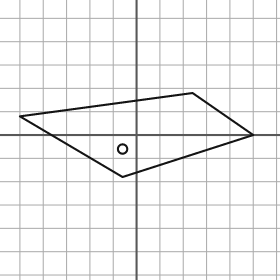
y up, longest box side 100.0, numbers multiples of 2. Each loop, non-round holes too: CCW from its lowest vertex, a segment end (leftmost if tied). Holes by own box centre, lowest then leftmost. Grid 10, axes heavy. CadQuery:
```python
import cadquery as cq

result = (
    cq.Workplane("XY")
    .moveTo(-6.0, -18.0)
    .lineTo(50.0, 0.0)
    .lineTo(24.0, 18.0)
    .lineTo(-50.0, 8.0)
    .close()
    .moveTo(-6.0, -6.0)
    .circle(2.0)
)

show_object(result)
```